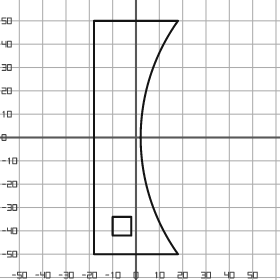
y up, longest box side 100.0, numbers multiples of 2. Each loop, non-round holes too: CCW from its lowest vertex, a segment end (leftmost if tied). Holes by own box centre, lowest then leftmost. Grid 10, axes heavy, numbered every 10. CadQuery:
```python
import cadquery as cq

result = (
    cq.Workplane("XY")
    .moveTo(-18.0, -50.0)
    .lineTo(18.0, -50.0)
    .threePointArc((2.0, 0.0), (18.0, 50.0))
    .lineTo(-18.0, 50.0)
    .close()
    .moveTo(-10.0, -42.0)
    .lineTo(-2.0, -42.0)
    .lineTo(-2.0, -34.0)
    .lineTo(-10.0, -34.0)
    .close()
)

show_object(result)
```